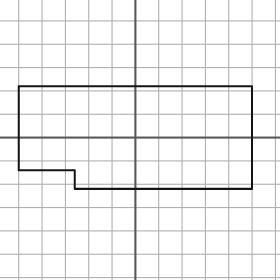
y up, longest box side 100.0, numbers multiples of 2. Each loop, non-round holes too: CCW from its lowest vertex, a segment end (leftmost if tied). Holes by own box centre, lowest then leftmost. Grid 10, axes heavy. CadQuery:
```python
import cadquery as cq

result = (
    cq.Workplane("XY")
    .moveTo(-26.0, -22.0)
    .lineTo(50.0, -22.0)
    .lineTo(50.0, 22.0)
    .lineTo(-50.0, 22.0)
    .lineTo(-50.0, -14.0)
    .lineTo(-26.0, -14.0)
    .close()
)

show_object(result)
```